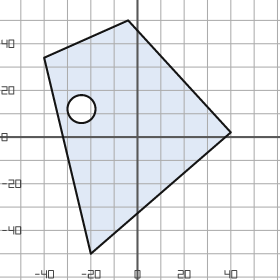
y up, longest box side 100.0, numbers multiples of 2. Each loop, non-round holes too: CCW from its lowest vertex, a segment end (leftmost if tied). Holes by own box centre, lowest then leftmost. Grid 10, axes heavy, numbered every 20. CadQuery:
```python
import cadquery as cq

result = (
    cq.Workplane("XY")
    .moveTo(-20.0, -50.0)
    .lineTo(40.0, 2.0)
    .lineTo(-4.0, 50.0)
    .lineTo(-40.0, 34.0)
    .close()
    .moveTo(-24.0, 12.0)
    .circle(6.0)
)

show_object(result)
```